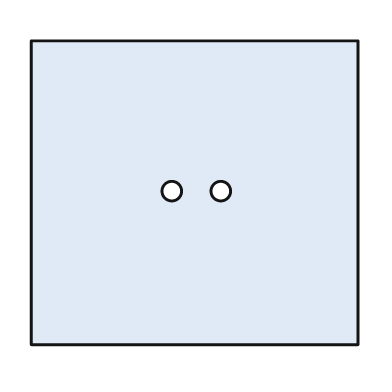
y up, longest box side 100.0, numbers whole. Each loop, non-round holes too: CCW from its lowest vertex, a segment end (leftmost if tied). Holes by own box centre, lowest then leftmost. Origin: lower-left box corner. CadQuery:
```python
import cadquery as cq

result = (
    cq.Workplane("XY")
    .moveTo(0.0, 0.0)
    .lineTo(100.0, 0.0)
    .lineTo(100.0, 93.0)
    .lineTo(0.0, 93.0)
    .close()
    .moveTo(43.0, 47.0)
    .circle(3.0)
    .moveTo(58.0, 47.0)
    .circle(3.0)
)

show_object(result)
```